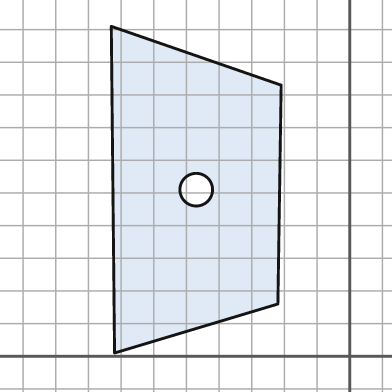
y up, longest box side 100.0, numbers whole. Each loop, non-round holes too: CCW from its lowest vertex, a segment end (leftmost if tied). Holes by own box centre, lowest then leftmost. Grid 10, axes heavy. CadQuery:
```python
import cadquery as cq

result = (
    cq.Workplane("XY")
    .moveTo(-72.0, 1.0)
    .lineTo(-22.0, 16.0)
    .lineTo(-21.0, 83.0)
    .lineTo(-73.0, 101.0)
    .close()
    .moveTo(-47.0, 51.0)
    .circle(5.0)
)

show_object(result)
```